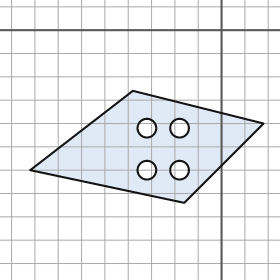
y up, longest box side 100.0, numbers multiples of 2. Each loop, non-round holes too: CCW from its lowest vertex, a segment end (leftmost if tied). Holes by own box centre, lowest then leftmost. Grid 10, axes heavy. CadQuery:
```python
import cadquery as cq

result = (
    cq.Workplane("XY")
    .moveTo(-16.0, -74.0)
    .lineTo(18.0, -40.0)
    .lineTo(-38.0, -26.0)
    .lineTo(-82.0, -60.0)
    .close()
    .moveTo(-32.0, -60.0)
    .circle(4.0)
    .moveTo(-18.0, -60.0)
    .circle(4.0)
    .moveTo(-32.0, -42.0)
    .circle(4.0)
    .moveTo(-18.0, -42.0)
    .circle(4.0)
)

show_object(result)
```